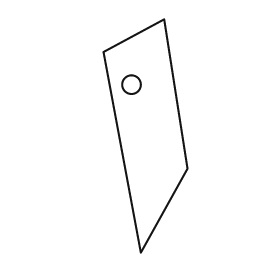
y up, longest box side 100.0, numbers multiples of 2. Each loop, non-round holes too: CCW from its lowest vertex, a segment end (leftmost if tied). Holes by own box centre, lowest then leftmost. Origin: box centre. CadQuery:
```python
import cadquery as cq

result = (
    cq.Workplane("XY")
    .moveTo(-2.0, -50.0)
    .lineTo(18.0, -14.0)
    .lineTo(8.0, 50.0)
    .lineTo(-18.0, 36.0)
    .close()
    .moveTo(-6.0, 22.0)
    .circle(4.0)
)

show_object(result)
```